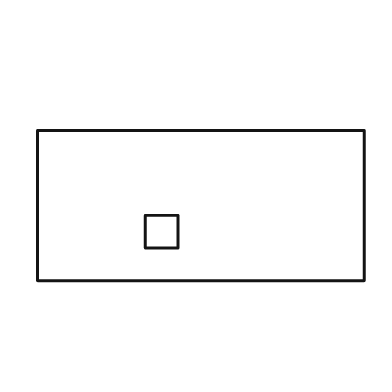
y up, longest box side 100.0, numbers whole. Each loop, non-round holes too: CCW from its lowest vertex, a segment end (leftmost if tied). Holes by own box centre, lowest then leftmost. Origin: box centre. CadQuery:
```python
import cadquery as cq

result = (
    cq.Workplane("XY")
    .moveTo(-50.0, -23.0)
    .lineTo(50.0, -23.0)
    .lineTo(50.0, 23.0)
    .lineTo(-50.0, 23.0)
    .close()
    .moveTo(-17.0, -13.0)
    .lineTo(-7.0, -13.0)
    .lineTo(-7.0, -3.0)
    .lineTo(-17.0, -3.0)
    .close()
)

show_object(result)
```